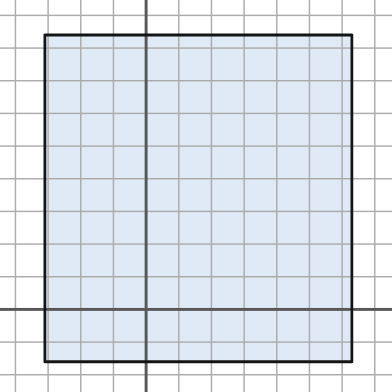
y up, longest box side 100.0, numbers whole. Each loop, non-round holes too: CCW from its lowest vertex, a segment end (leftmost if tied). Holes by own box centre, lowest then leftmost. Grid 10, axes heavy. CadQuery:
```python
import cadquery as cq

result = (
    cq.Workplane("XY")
    .moveTo(-31.0, -16.0)
    .lineTo(63.0, -16.0)
    .lineTo(63.0, 84.0)
    .lineTo(-31.0, 84.0)
    .close()
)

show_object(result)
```